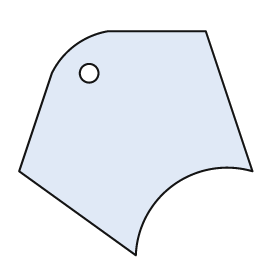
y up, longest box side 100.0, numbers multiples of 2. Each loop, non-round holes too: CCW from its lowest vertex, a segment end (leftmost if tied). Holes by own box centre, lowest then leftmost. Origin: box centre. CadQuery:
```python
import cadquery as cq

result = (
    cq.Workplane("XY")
    .moveTo(0.0, -48.0)
    .threePointArc((16.0, -18.0), (50.0, -12.0))
    .lineTo(30.0, 48.0)
    .lineTo(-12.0, 48.0)
    .threePointArc((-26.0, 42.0), (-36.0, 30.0))
    .lineTo(-50.0, -12.0)
    .close()
    .moveTo(-20.0, 30.0)
    .circle(4.0)
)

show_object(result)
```